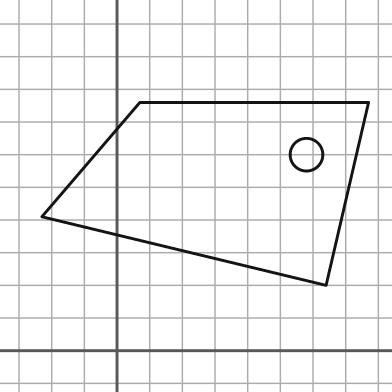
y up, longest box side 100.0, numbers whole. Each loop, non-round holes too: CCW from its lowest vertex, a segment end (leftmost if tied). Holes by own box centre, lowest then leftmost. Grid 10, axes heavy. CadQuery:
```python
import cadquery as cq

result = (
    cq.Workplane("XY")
    .moveTo(64.0, 20.0)
    .lineTo(77.0, 76.0)
    .lineTo(7.0, 76.0)
    .lineTo(-23.0, 41.0)
    .close()
    .moveTo(58.0, 60.0)
    .circle(5.0)
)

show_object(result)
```